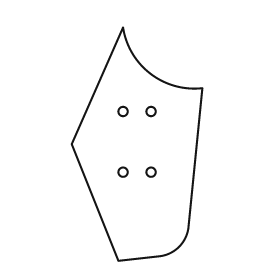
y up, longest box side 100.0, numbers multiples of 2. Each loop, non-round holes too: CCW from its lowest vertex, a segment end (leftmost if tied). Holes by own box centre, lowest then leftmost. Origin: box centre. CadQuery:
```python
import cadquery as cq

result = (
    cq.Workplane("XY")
    .moveTo(-8.0, -50.0)
    .lineTo(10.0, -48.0)
    .threePointArc((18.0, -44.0), (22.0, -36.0))
    .lineTo(28.0, 24.0)
    .threePointArc((6.0, 30.0), (-6.0, 50.0))
    .lineTo(-28.0, 0.0)
    .close()
    .moveTo(-6.0, -12.0)
    .circle(2.0)
    .moveTo(6.0, -12.0)
    .circle(2.0)
    .moveTo(-6.0, 14.0)
    .circle(2.0)
    .moveTo(6.0, 14.0)
    .circle(2.0)
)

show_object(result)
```